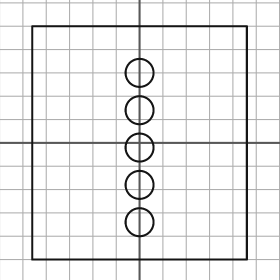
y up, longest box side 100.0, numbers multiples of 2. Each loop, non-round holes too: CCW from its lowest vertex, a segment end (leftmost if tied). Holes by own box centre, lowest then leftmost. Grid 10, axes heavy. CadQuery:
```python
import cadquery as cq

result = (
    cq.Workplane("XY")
    .moveTo(-46.0, -50.0)
    .lineTo(46.0, -50.0)
    .lineTo(46.0, 50.0)
    .lineTo(-46.0, 50.0)
    .close()
    .moveTo(0.0, -34.0)
    .circle(6.0)
    .moveTo(0.0, -18.0)
    .circle(6.0)
    .moveTo(0.0, -2.0)
    .circle(6.0)
    .moveTo(0.0, 14.0)
    .circle(6.0)
    .moveTo(0.0, 30.0)
    .circle(6.0)
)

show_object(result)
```